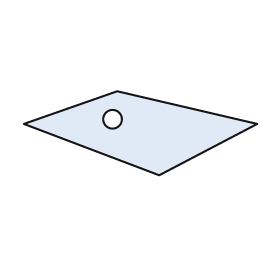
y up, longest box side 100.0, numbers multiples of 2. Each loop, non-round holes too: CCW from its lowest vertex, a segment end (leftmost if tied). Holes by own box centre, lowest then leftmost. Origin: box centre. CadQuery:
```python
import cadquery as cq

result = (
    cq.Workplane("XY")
    .moveTo(8.0, -18.0)
    .lineTo(50.0, 4.0)
    .lineTo(-10.0, 18.0)
    .lineTo(-50.0, 4.0)
    .close()
    .moveTo(-12.0, 6.0)
    .circle(4.0)
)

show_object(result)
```